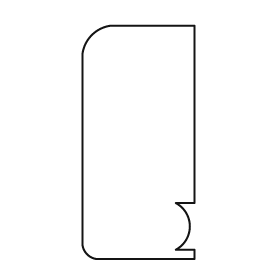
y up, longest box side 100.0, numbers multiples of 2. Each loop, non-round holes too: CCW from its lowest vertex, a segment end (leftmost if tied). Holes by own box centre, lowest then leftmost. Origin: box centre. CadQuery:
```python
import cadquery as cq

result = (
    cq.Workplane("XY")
    .moveTo(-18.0, -50.0)
    .lineTo(24.0, -50.0)
    .lineTo(24.0, -46.0)
    .lineTo(16.0, -46.0)
    .threePointArc((22.0, -36.0), (16.0, -26.0))
    .lineTo(24.0, -26.0)
    .lineTo(24.0, 50.0)
    .lineTo(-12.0, 50.0)
    .threePointArc((-20.0, 46.0), (-24.0, 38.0))
    .lineTo(-24.0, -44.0)
    .threePointArc((-22.0, -48.0), (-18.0, -50.0))
    .close()
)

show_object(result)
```